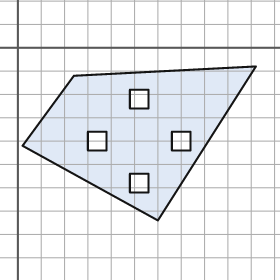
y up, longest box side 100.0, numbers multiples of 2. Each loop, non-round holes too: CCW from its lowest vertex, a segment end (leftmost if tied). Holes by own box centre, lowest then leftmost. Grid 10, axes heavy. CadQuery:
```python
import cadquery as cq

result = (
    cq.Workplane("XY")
    .moveTo(60.0, -74.0)
    .lineTo(102.0, -8.0)
    .lineTo(24.0, -12.0)
    .lineTo(2.0, -42.0)
    .close()
    .moveTo(48.0, -62.0)
    .lineTo(56.0, -62.0)
    .lineTo(56.0, -54.0)
    .lineTo(48.0, -54.0)
    .close()
    .moveTo(30.0, -44.0)
    .lineTo(38.0, -44.0)
    .lineTo(38.0, -36.0)
    .lineTo(30.0, -36.0)
    .close()
    .moveTo(66.0, -44.0)
    .lineTo(74.0, -44.0)
    .lineTo(74.0, -36.0)
    .lineTo(66.0, -36.0)
    .close()
    .moveTo(48.0, -26.0)
    .lineTo(56.0, -26.0)
    .lineTo(56.0, -18.0)
    .lineTo(48.0, -18.0)
    .close()
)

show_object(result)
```